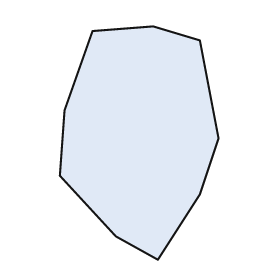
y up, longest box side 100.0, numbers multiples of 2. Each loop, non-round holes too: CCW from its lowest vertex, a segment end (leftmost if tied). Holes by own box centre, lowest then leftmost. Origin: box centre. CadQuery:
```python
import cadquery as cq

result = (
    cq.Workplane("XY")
    .moveTo(8.0, -50.0)
    .lineTo(26.0, -22.0)
    .lineTo(34.0, 2.0)
    .lineTo(26.0, 44.0)
    .lineTo(6.0, 50.0)
    .lineTo(-20.0, 48.0)
    .lineTo(-32.0, 14.0)
    .lineTo(-34.0, -14.0)
    .lineTo(-10.0, -40.0)
    .close()
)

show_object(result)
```